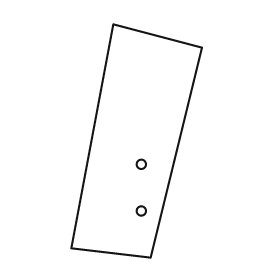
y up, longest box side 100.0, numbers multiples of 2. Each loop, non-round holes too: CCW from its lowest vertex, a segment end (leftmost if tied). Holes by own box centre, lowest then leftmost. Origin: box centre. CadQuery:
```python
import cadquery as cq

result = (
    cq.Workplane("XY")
    .moveTo(6.0, -50.0)
    .lineTo(28.0, 40.0)
    .lineTo(-10.0, 50.0)
    .lineTo(-28.0, -46.0)
    .close()
    .moveTo(2.0, -30.0)
    .circle(2.0)
    .moveTo(2.0, -10.0)
    .circle(2.0)
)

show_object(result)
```